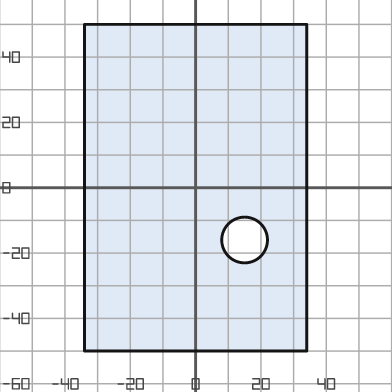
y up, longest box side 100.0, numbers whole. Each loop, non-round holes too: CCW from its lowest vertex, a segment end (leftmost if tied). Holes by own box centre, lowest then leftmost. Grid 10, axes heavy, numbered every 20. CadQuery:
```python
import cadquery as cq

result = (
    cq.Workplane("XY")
    .moveTo(-34.0, -50.0)
    .lineTo(34.0, -50.0)
    .lineTo(34.0, 50.0)
    .lineTo(-34.0, 50.0)
    .close()
    .moveTo(15.0, -16.0)
    .circle(7.0)
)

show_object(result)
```